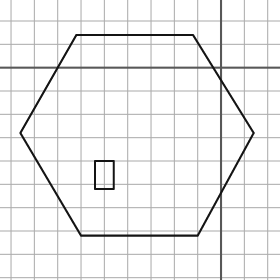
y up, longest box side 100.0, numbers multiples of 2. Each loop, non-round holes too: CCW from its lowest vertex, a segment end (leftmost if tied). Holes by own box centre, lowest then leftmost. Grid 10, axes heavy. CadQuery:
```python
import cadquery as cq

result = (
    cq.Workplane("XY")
    .moveTo(-60.0, -72.0)
    .lineTo(-10.0, -72.0)
    .lineTo(14.0, -28.0)
    .lineTo(-12.0, 14.0)
    .lineTo(-62.0, 14.0)
    .lineTo(-86.0, -28.0)
    .close()
    .moveTo(-54.0, -52.0)
    .lineTo(-46.0, -52.0)
    .lineTo(-46.0, -40.0)
    .lineTo(-54.0, -40.0)
    .close()
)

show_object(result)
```